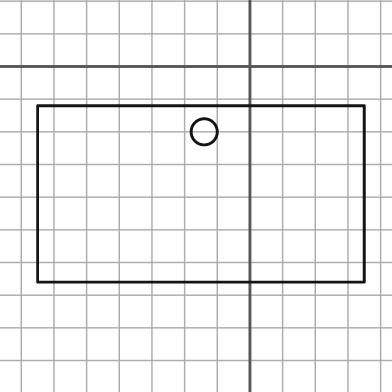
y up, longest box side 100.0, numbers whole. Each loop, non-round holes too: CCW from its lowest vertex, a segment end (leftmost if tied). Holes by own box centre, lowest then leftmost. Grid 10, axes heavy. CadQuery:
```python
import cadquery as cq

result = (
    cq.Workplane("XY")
    .moveTo(-65.0, -66.0)
    .lineTo(35.0, -66.0)
    .lineTo(35.0, -12.0)
    .lineTo(-65.0, -12.0)
    .close()
    .moveTo(-14.0, -20.0)
    .circle(4.0)
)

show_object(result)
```